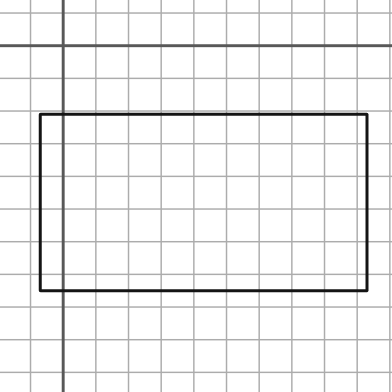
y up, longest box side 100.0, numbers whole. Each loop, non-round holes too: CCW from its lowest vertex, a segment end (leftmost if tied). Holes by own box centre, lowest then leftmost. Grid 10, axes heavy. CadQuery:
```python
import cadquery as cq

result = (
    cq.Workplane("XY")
    .moveTo(-7.0, -75.0)
    .lineTo(93.0, -75.0)
    .lineTo(93.0, -21.0)
    .lineTo(-7.0, -21.0)
    .close()
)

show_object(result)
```